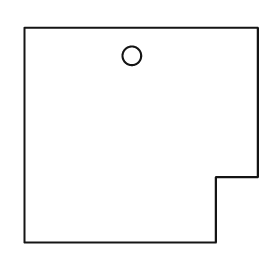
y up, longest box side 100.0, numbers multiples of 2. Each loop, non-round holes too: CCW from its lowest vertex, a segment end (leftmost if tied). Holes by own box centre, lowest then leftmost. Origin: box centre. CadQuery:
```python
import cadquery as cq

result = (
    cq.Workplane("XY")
    .moveTo(-50.0, -46.0)
    .lineTo(32.0, -46.0)
    .lineTo(32.0, -18.0)
    .lineTo(50.0, -18.0)
    .lineTo(50.0, 46.0)
    .lineTo(-50.0, 46.0)
    .close()
    .moveTo(-4.0, 34.0)
    .circle(4.0)
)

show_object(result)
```